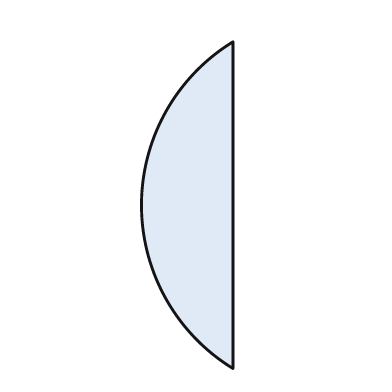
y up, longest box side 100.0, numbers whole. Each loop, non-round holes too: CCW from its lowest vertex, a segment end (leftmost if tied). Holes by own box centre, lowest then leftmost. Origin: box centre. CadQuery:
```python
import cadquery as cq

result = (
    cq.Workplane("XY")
    .moveTo(14.0, -50.0)
    .lineTo(14.0, 50.0)
    .threePointArc((-14.0, 0.0), (14.0, -50.0))
    .close()
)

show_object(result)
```